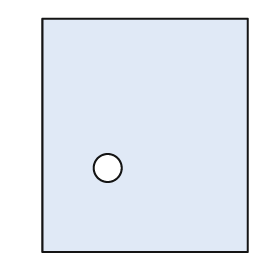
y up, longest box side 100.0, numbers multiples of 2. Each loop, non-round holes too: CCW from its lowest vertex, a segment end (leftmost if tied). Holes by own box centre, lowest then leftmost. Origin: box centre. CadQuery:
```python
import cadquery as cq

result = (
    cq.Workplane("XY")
    .moveTo(-44.0, -50.0)
    .lineTo(44.0, -50.0)
    .lineTo(44.0, 50.0)
    .lineTo(-44.0, 50.0)
    .close()
    .moveTo(-16.0, -14.0)
    .circle(6.0)
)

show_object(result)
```